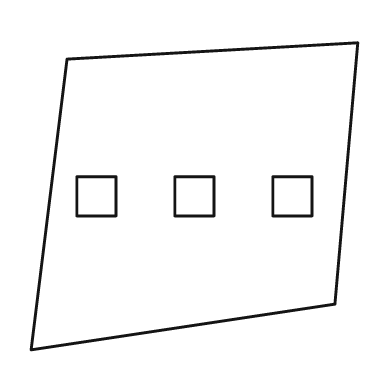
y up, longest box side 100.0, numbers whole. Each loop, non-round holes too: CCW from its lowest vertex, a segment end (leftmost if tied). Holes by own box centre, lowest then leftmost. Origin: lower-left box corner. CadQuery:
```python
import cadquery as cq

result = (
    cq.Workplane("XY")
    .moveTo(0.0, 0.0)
    .lineTo(93.0, 14.0)
    .lineTo(100.0, 94.0)
    .lineTo(11.0, 89.0)
    .close()
    .moveTo(14.0, 41.0)
    .lineTo(26.0, 41.0)
    .lineTo(26.0, 53.0)
    .lineTo(14.0, 53.0)
    .close()
    .moveTo(44.0, 41.0)
    .lineTo(56.0, 41.0)
    .lineTo(56.0, 53.0)
    .lineTo(44.0, 53.0)
    .close()
    .moveTo(74.0, 41.0)
    .lineTo(86.0, 41.0)
    .lineTo(86.0, 53.0)
    .lineTo(74.0, 53.0)
    .close()
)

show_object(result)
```